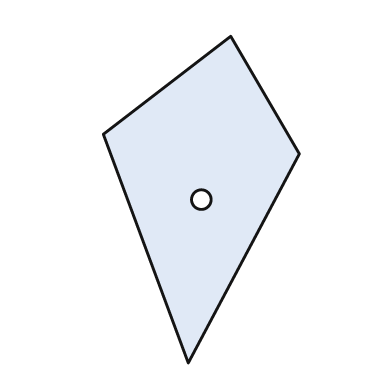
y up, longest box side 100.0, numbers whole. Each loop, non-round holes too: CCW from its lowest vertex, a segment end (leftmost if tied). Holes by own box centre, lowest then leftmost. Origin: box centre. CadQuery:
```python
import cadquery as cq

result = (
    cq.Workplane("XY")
    .moveTo(-4.0, -50.0)
    .lineTo(30.0, 14.0)
    .lineTo(9.0, 50.0)
    .lineTo(-30.0, 20.0)
    .close()
    .moveTo(0.0, 0.0)
    .circle(3.0)
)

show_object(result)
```